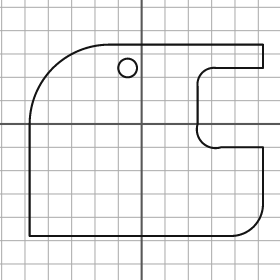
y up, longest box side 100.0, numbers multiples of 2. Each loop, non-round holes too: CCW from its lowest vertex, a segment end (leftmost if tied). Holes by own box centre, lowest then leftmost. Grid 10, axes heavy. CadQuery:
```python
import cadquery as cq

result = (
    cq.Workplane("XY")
    .moveTo(-48.0, -48.0)
    .lineTo(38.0, -48.0)
    .threePointArc((48.0, -44.0), (52.0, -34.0))
    .lineTo(52.0, -10.0)
    .lineTo(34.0, -10.0)
    .threePointArc((26.0, -8.0), (24.0, 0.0))
    .lineTo(24.0, 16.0)
    .threePointArc((26.0, 22.0), (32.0, 24.0))
    .lineTo(52.0, 24.0)
    .lineTo(52.0, 34.0)
    .lineTo(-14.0, 34.0)
    .threePointArc((-38.0, 24.0), (-48.0, 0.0))
    .close()
    .moveTo(-6.0, 24.0)
    .circle(4.0)
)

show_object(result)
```